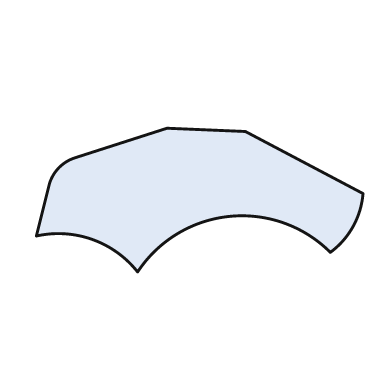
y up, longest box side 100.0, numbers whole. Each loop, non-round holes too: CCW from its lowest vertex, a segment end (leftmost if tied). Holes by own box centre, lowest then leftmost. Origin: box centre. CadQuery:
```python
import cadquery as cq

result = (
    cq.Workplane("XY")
    .moveTo(-19.0, -22.0)
    .threePointArc((9.0, -5.0), (40.0, -16.0))
    .threePointArc((47.0, -8.0), (50.0, 2.0))
    .lineTo(14.0, 21.0)
    .lineTo(-10.0, 22.0)
    .lineTo(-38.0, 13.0)
    .threePointArc((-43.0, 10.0), (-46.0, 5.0))
    .lineTo(-50.0, -11.0)
    .threePointArc((-33.0, -12.0), (-19.0, -22.0))
    .close()
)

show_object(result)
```